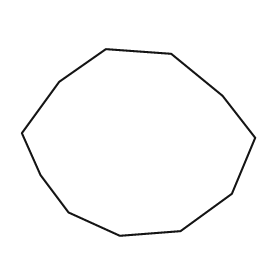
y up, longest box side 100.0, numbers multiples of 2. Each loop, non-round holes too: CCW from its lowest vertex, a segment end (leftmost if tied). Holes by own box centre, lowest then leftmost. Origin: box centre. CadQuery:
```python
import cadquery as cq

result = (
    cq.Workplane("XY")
    .moveTo(-8.0, -40.0)
    .lineTo(18.0, -38.0)
    .lineTo(40.0, -22.0)
    .lineTo(50.0, 2.0)
    .lineTo(36.0, 20.0)
    .lineTo(14.0, 38.0)
    .lineTo(-14.0, 40.0)
    .lineTo(-34.0, 26.0)
    .lineTo(-50.0, 4.0)
    .lineTo(-42.0, -14.0)
    .lineTo(-30.0, -30.0)
    .close()
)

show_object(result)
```